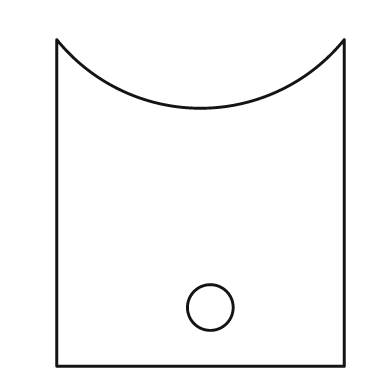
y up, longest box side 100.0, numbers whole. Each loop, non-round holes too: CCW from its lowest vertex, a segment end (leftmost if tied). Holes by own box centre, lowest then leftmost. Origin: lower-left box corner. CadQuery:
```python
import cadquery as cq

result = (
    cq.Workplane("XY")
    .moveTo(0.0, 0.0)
    .lineTo(88.0, 0.0)
    .lineTo(88.0, 100.0)
    .threePointArc((44.0, 79.0), (0.0, 100.0))
    .close()
    .moveTo(47.0, 18.0)
    .circle(7.0)
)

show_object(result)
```